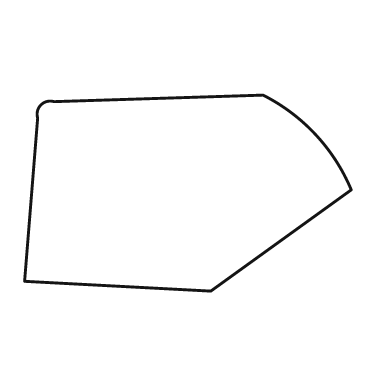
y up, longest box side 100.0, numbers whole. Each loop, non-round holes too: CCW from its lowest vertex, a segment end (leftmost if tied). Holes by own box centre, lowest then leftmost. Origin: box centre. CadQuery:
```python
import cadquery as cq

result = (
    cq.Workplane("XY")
    .moveTo(7.0, -30.0)
    .lineTo(50.0, 1.0)
    .threePointArc((39.0, 18.0), (23.0, 30.0))
    .lineTo(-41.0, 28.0)
    .threePointArc((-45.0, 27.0), (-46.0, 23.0))
    .lineTo(-50.0, -27.0)
    .close()
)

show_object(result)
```